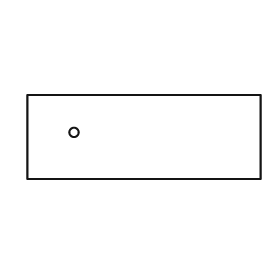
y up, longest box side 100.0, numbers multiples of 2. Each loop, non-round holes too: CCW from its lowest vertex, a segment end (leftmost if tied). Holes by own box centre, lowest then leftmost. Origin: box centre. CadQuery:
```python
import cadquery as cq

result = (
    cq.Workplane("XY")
    .moveTo(-50.0, -18.0)
    .lineTo(50.0, -18.0)
    .lineTo(50.0, 18.0)
    .lineTo(-50.0, 18.0)
    .close()
    .moveTo(-30.0, 2.0)
    .circle(2.0)
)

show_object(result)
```